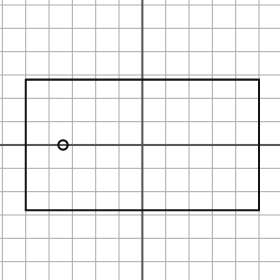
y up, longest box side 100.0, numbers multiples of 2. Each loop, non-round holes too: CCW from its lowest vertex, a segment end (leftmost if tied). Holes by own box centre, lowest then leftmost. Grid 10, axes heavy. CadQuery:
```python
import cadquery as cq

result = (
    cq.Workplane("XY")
    .moveTo(-50.0, -28.0)
    .lineTo(50.0, -28.0)
    .lineTo(50.0, 28.0)
    .lineTo(-50.0, 28.0)
    .close()
    .moveTo(-34.0, 0.0)
    .circle(2.0)
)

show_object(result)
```